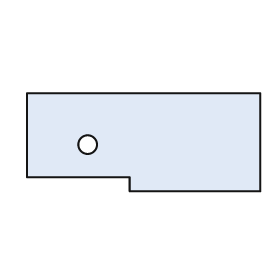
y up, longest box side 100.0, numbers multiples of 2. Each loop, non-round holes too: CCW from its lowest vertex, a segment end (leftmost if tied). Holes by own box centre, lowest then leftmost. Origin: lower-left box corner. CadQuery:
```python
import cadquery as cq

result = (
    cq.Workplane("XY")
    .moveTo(44.0, 0.0)
    .lineTo(100.0, 0.0)
    .lineTo(100.0, 42.0)
    .lineTo(0.0, 42.0)
    .lineTo(0.0, 6.0)
    .lineTo(44.0, 6.0)
    .close()
    .moveTo(26.0, 20.0)
    .circle(4.0)
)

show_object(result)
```